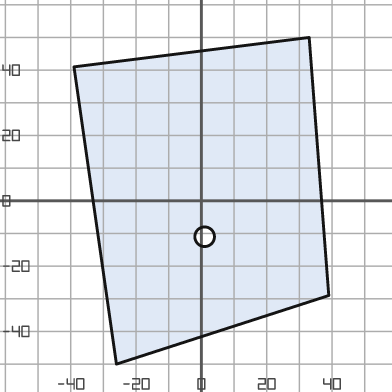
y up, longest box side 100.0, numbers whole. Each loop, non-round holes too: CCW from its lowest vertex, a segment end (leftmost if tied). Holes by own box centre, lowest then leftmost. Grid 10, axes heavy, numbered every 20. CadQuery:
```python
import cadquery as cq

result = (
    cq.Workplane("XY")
    .moveTo(-26.0, -50.0)
    .lineTo(39.0, -29.0)
    .lineTo(33.0, 50.0)
    .lineTo(-39.0, 41.0)
    .close()
    .moveTo(1.0, -11.0)
    .circle(3.0)
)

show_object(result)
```